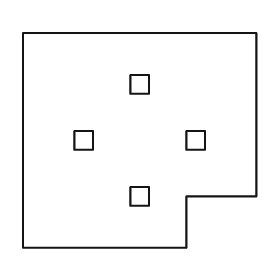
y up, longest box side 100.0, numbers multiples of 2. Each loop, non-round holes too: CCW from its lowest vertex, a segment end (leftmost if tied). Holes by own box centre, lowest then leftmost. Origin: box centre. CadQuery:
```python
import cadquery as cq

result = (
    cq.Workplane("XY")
    .moveTo(-50.0, -46.0)
    .lineTo(20.0, -46.0)
    .lineTo(20.0, -24.0)
    .lineTo(50.0, -24.0)
    .lineTo(50.0, 46.0)
    .lineTo(-50.0, 46.0)
    .close()
    .moveTo(-4.0, -28.0)
    .lineTo(4.0, -28.0)
    .lineTo(4.0, -20.0)
    .lineTo(-4.0, -20.0)
    .close()
    .moveTo(-28.0, -4.0)
    .lineTo(-20.0, -4.0)
    .lineTo(-20.0, 4.0)
    .lineTo(-28.0, 4.0)
    .close()
    .moveTo(20.0, -4.0)
    .lineTo(28.0, -4.0)
    .lineTo(28.0, 4.0)
    .lineTo(20.0, 4.0)
    .close()
    .moveTo(-4.0, 20.0)
    .lineTo(4.0, 20.0)
    .lineTo(4.0, 28.0)
    .lineTo(-4.0, 28.0)
    .close()
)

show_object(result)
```